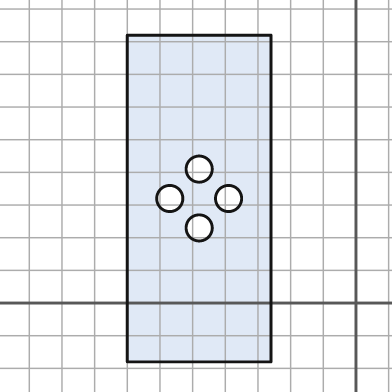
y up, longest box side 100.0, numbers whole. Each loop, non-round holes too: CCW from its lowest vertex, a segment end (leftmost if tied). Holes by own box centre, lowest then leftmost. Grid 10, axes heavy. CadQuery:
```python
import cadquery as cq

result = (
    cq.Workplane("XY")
    .moveTo(-70.0, -18.0)
    .lineTo(-26.0, -18.0)
    .lineTo(-26.0, 82.0)
    .lineTo(-70.0, 82.0)
    .close()
    .moveTo(-48.0, 23.0)
    .circle(4.0)
    .moveTo(-57.0, 32.0)
    .circle(4.0)
    .moveTo(-39.0, 32.0)
    .circle(4.0)
    .moveTo(-48.0, 41.0)
    .circle(4.0)
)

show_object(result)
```